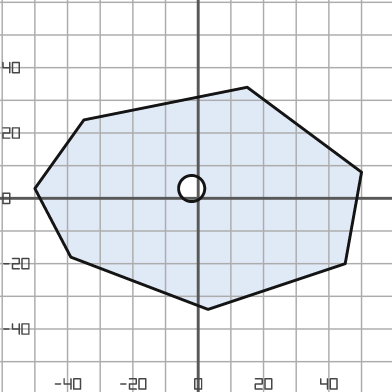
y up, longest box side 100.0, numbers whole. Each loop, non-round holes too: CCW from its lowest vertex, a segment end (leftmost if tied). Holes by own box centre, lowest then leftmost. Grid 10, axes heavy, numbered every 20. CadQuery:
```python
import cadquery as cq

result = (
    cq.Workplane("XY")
    .moveTo(3.0, -34.0)
    .lineTo(45.0, -20.0)
    .lineTo(50.0, 8.0)
    .lineTo(15.0, 34.0)
    .lineTo(-35.0, 24.0)
    .lineTo(-50.0, 3.0)
    .lineTo(-39.0, -18.0)
    .close()
    .moveTo(-2.0, 3.0)
    .circle(4.0)
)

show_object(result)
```